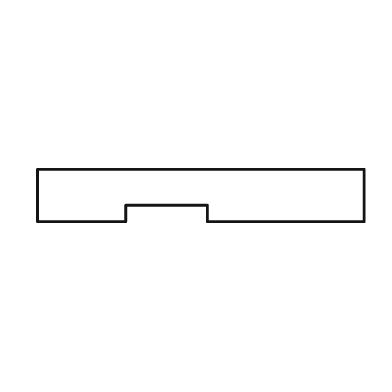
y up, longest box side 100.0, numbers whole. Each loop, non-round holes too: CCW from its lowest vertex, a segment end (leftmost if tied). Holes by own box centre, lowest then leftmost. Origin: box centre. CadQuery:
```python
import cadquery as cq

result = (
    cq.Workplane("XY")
    .moveTo(-50.0, -8.0)
    .lineTo(-23.0, -8.0)
    .lineTo(-23.0, -3.0)
    .lineTo(2.0, -3.0)
    .lineTo(2.0, -8.0)
    .lineTo(50.0, -8.0)
    .lineTo(50.0, 8.0)
    .lineTo(-50.0, 8.0)
    .close()
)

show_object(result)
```